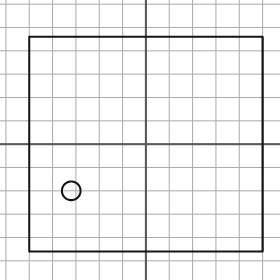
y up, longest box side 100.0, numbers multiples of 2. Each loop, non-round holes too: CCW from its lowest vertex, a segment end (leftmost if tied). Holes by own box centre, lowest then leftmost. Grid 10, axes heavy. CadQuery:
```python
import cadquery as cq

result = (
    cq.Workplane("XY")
    .moveTo(-50.0, -46.0)
    .lineTo(50.0, -46.0)
    .lineTo(50.0, 46.0)
    .lineTo(-50.0, 46.0)
    .close()
    .moveTo(-32.0, -20.0)
    .circle(4.0)
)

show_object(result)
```